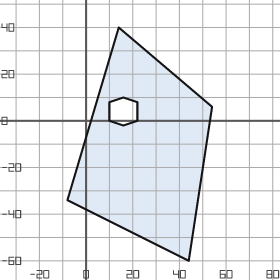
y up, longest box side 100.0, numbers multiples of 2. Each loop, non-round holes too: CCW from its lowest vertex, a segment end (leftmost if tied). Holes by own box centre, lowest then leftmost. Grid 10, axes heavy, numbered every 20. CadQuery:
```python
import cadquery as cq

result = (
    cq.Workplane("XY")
    .moveTo(44.0, -60.0)
    .lineTo(54.0, 6.0)
    .lineTo(14.0, 40.0)
    .lineTo(-8.0, -34.0)
    .close()
    .moveTo(16.0, -2.0)
    .lineTo(22.0, 0.0)
    .lineTo(22.0, 8.0)
    .lineTo(16.0, 10.0)
    .lineTo(10.0, 8.0)
    .lineTo(10.0, 0.0)
    .close()
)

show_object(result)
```